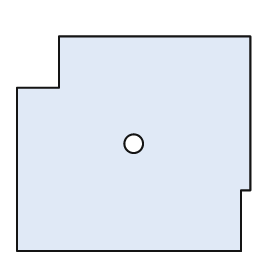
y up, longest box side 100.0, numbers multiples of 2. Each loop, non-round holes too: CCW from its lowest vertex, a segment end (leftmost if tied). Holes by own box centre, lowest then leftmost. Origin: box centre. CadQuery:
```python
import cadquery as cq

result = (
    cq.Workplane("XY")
    .moveTo(-50.0, -46.0)
    .lineTo(46.0, -46.0)
    .lineTo(46.0, -20.0)
    .lineTo(50.0, -20.0)
    .lineTo(50.0, 46.0)
    .lineTo(-32.0, 46.0)
    .lineTo(-32.0, 24.0)
    .lineTo(-50.0, 24.0)
    .close()
    .moveTo(0.0, 0.0)
    .circle(4.0)
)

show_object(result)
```